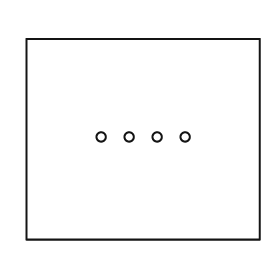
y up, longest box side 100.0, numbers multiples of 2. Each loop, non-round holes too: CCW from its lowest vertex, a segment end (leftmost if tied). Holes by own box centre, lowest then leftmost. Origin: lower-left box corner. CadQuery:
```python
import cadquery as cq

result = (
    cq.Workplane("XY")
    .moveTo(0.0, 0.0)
    .lineTo(100.0, 0.0)
    .lineTo(100.0, 86.0)
    .lineTo(0.0, 86.0)
    .close()
    .moveTo(32.0, 44.0)
    .circle(2.0)
    .moveTo(44.0, 44.0)
    .circle(2.0)
    .moveTo(56.0, 44.0)
    .circle(2.0)
    .moveTo(68.0, 44.0)
    .circle(2.0)
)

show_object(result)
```